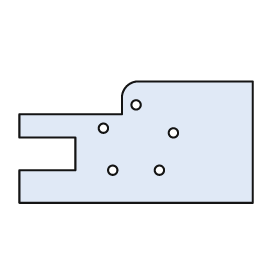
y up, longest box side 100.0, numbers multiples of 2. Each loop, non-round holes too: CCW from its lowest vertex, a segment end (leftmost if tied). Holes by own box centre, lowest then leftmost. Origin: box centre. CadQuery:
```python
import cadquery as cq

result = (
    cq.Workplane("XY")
    .moveTo(-50.0, -26.0)
    .lineTo(50.0, -26.0)
    .lineTo(50.0, 26.0)
    .lineTo(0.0, 26.0)
    .threePointArc((-4.0, 24.0), (-6.0, 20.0))
    .lineTo(-6.0, 12.0)
    .lineTo(-50.0, 12.0)
    .lineTo(-50.0, 2.0)
    .lineTo(-26.0, 2.0)
    .lineTo(-26.0, -12.0)
    .lineTo(-50.0, -12.0)
    .close()
    .moveTo(-10.0, -12.0)
    .circle(2.0)
    .moveTo(10.0, -12.0)
    .circle(2.0)
    .moveTo(16.0, 4.0)
    .circle(2.0)
    .moveTo(-14.0, 6.0)
    .circle(2.0)
    .moveTo(0.0, 16.0)
    .circle(2.0)
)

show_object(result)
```